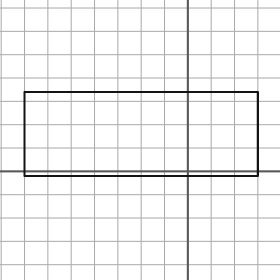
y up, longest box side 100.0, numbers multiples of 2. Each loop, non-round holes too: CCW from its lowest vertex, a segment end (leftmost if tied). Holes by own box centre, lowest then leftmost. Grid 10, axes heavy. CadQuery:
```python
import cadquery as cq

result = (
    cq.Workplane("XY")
    .moveTo(-70.0, -2.0)
    .lineTo(30.0, -2.0)
    .lineTo(30.0, 34.0)
    .lineTo(-70.0, 34.0)
    .close()
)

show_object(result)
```